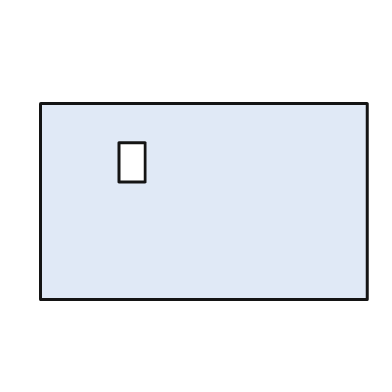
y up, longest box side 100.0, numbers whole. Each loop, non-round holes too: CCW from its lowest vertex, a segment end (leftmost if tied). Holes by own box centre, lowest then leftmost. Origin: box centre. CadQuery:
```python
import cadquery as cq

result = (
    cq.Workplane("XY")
    .moveTo(-50.0, -30.0)
    .lineTo(50.0, -30.0)
    .lineTo(50.0, 30.0)
    .lineTo(-50.0, 30.0)
    .close()
    .moveTo(-26.0, 6.0)
    .lineTo(-18.0, 6.0)
    .lineTo(-18.0, 18.0)
    .lineTo(-26.0, 18.0)
    .close()
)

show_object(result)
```